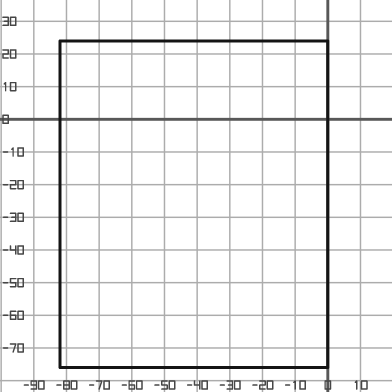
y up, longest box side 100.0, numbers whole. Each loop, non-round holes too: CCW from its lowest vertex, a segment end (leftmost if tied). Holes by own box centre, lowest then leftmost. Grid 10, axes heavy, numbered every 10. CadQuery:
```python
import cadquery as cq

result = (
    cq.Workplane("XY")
    .moveTo(-82.0, -76.0)
    .lineTo(0.0, -76.0)
    .lineTo(0.0, 24.0)
    .lineTo(-82.0, 24.0)
    .close()
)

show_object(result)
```